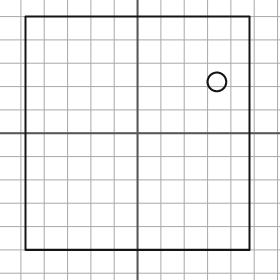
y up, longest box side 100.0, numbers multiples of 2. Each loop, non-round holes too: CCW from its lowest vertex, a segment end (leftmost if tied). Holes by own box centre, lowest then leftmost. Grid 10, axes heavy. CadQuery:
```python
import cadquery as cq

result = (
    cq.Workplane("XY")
    .moveTo(-48.0, -50.0)
    .lineTo(48.0, -50.0)
    .lineTo(48.0, 50.0)
    .lineTo(-48.0, 50.0)
    .close()
    .moveTo(34.0, 22.0)
    .circle(4.0)
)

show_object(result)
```